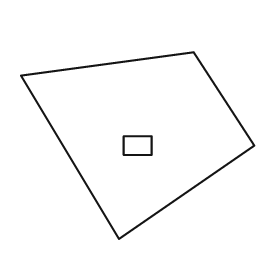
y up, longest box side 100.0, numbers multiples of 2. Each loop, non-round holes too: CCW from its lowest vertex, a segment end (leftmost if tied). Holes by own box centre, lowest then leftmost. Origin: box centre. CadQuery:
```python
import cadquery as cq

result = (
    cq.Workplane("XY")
    .moveTo(-8.0, -40.0)
    .lineTo(50.0, 0.0)
    .lineTo(24.0, 40.0)
    .lineTo(-50.0, 30.0)
    .close()
    .moveTo(-6.0, -4.0)
    .lineTo(6.0, -4.0)
    .lineTo(6.0, 4.0)
    .lineTo(-6.0, 4.0)
    .close()
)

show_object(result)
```